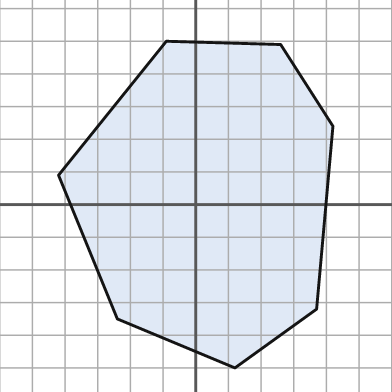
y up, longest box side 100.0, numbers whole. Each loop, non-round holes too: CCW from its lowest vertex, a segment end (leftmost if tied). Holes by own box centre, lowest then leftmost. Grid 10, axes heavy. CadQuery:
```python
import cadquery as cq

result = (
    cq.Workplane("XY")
    .moveTo(12.0, -50.0)
    .lineTo(37.0, -32.0)
    .lineTo(42.0, 24.0)
    .lineTo(26.0, 49.0)
    .lineTo(-9.0, 50.0)
    .lineTo(-42.0, 9.0)
    .lineTo(-24.0, -35.0)
    .close()
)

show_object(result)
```